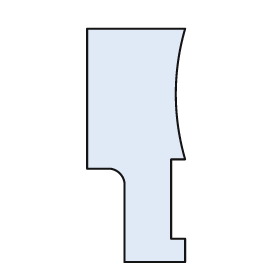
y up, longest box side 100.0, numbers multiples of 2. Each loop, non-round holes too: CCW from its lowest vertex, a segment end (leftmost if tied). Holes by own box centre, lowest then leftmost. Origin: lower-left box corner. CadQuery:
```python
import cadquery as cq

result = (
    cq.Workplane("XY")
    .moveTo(16.0, 0.0)
    .lineTo(42.0, 0.0)
    .lineTo(42.0, 10.0)
    .lineTo(36.0, 10.0)
    .lineTo(36.0, 44.0)
    .lineTo(42.0, 44.0)
    .threePointArc((38.0, 72.0), (42.0, 100.0))
    .lineTo(0.0, 100.0)
    .lineTo(0.0, 40.0)
    .lineTo(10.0, 40.0)
    .threePointArc((14.0, 38.0), (16.0, 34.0))
    .close()
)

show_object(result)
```